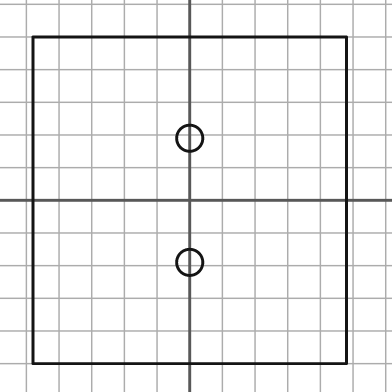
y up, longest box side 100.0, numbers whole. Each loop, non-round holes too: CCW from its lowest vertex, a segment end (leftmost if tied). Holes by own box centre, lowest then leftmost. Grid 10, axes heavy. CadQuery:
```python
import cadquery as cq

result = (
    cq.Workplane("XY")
    .moveTo(-48.0, -50.0)
    .lineTo(48.0, -50.0)
    .lineTo(48.0, 50.0)
    .lineTo(-48.0, 50.0)
    .close()
    .moveTo(0.0, -19.0)
    .circle(4.0)
    .moveTo(0.0, 19.0)
    .circle(4.0)
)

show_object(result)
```